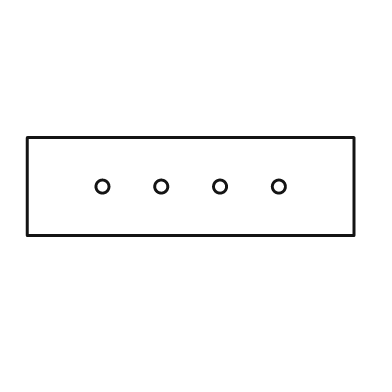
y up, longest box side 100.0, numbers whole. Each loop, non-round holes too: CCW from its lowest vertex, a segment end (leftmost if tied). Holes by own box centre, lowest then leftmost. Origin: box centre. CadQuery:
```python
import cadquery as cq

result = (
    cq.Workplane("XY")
    .moveTo(-50.0, -15.0)
    .lineTo(50.0, -15.0)
    .lineTo(50.0, 15.0)
    .lineTo(-50.0, 15.0)
    .close()
    .moveTo(-27.0, 0.0)
    .circle(2.0)
    .moveTo(-9.0, 0.0)
    .circle(2.0)
    .moveTo(9.0, 0.0)
    .circle(2.0)
    .moveTo(27.0, 0.0)
    .circle(2.0)
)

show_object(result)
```